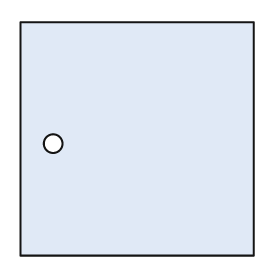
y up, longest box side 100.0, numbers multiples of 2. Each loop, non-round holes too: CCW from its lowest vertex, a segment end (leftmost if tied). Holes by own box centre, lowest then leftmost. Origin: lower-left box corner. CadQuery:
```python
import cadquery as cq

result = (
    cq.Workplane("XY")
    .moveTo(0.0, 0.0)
    .lineTo(100.0, 0.0)
    .lineTo(100.0, 100.0)
    .lineTo(0.0, 100.0)
    .close()
    .moveTo(14.0, 48.0)
    .circle(4.0)
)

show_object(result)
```